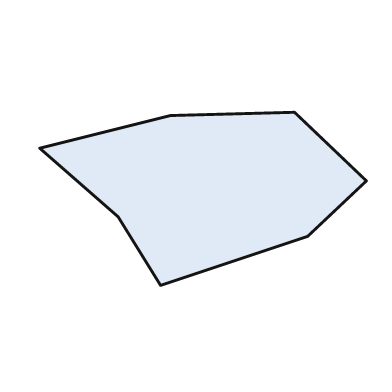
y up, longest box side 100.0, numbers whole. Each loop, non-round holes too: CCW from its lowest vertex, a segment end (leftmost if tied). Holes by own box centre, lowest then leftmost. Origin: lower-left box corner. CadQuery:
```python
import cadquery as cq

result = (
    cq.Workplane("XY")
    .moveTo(37.0, 0.0)
    .lineTo(82.0, 15.0)
    .lineTo(100.0, 32.0)
    .lineTo(78.0, 53.0)
    .lineTo(40.0, 52.0)
    .lineTo(0.0, 42.0)
    .lineTo(24.0, 21.0)
    .close()
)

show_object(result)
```